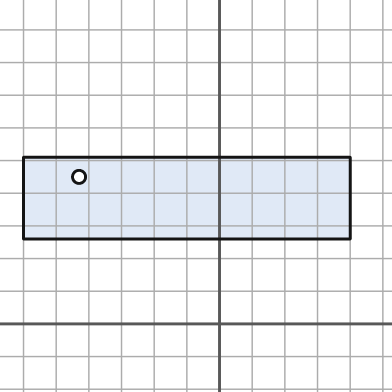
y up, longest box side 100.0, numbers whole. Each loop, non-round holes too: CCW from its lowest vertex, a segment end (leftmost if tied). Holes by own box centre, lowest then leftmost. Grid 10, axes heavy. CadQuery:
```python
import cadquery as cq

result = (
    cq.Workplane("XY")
    .moveTo(-60.0, 26.0)
    .lineTo(40.0, 26.0)
    .lineTo(40.0, 51.0)
    .lineTo(-60.0, 51.0)
    .close()
    .moveTo(-43.0, 45.0)
    .circle(2.0)
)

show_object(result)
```